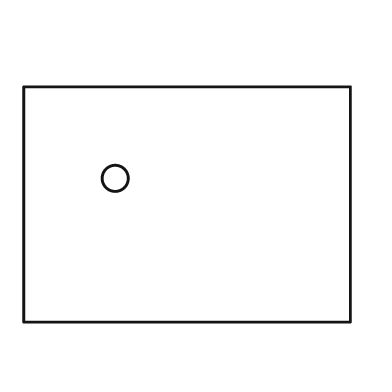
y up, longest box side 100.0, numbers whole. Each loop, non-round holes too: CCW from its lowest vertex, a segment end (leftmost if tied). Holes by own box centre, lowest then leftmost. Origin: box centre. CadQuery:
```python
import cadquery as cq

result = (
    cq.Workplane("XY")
    .moveTo(-50.0, -36.0)
    .lineTo(50.0, -36.0)
    .lineTo(50.0, 36.0)
    .lineTo(-50.0, 36.0)
    .close()
    .moveTo(-22.0, 8.0)
    .circle(4.0)
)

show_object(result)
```